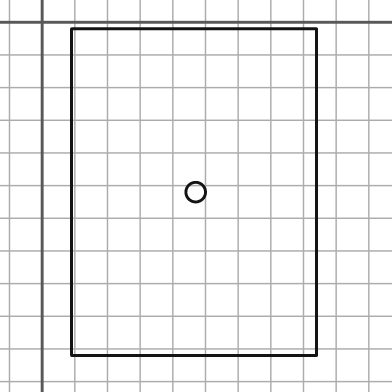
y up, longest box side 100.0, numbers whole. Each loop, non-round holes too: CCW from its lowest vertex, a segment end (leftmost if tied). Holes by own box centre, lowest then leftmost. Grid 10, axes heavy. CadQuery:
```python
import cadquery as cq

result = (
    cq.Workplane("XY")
    .moveTo(9.0, -102.0)
    .lineTo(84.0, -102.0)
    .lineTo(84.0, -2.0)
    .lineTo(9.0, -2.0)
    .close()
    .moveTo(47.0, -52.0)
    .circle(3.0)
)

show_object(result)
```